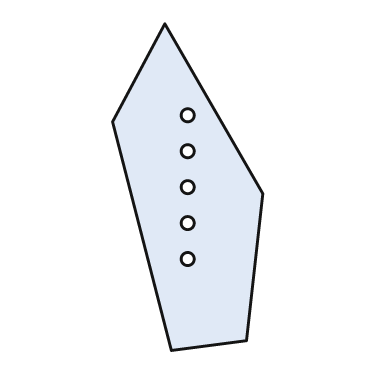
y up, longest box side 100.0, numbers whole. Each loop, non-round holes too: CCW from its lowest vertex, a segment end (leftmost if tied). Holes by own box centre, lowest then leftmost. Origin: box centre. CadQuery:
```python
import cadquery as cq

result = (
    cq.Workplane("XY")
    .moveTo(-5.0, -50.0)
    .lineTo(18.0, -47.0)
    .lineTo(23.0, -2.0)
    .lineTo(-7.0, 50.0)
    .lineTo(-23.0, 20.0)
    .close()
    .moveTo(0.0, -22.0)
    .circle(2.0)
    .moveTo(0.0, -11.0)
    .circle(2.0)
    .moveTo(0.0, 0.0)
    .circle(2.0)
    .moveTo(0.0, 11.0)
    .circle(2.0)
    .moveTo(0.0, 22.0)
    .circle(2.0)
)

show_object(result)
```